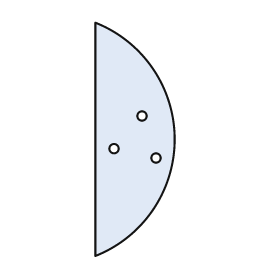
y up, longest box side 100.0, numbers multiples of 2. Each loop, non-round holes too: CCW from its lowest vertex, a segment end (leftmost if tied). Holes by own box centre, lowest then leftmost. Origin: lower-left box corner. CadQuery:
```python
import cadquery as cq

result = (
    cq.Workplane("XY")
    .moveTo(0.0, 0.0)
    .threePointArc((34.0, 50.0), (0.0, 100.0))
    .close()
    .moveTo(26.0, 42.0)
    .circle(2.0)
    .moveTo(8.0, 46.0)
    .circle(2.0)
    .moveTo(20.0, 60.0)
    .circle(2.0)
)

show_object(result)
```